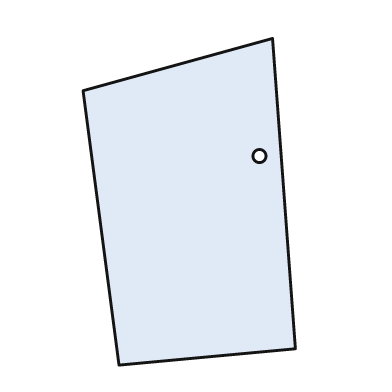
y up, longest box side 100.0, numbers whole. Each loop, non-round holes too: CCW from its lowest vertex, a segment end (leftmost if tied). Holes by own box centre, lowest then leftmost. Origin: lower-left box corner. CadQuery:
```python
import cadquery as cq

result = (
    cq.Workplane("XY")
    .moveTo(11.0, 0.0)
    .lineTo(65.0, 5.0)
    .lineTo(58.0, 100.0)
    .lineTo(0.0, 84.0)
    .close()
    .moveTo(54.0, 64.0)
    .circle(2.0)
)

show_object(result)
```